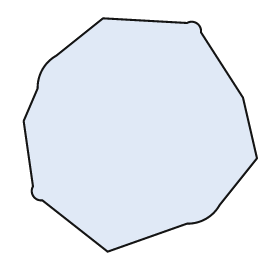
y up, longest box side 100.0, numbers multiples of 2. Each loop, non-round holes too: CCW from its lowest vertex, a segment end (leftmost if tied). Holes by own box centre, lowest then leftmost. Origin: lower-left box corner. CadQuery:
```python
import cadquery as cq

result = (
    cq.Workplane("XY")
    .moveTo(36.0, 0.0)
    .lineTo(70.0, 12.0)
    .threePointArc((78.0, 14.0), (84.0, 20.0))
    .lineTo(100.0, 40.0)
    .lineTo(94.0, 66.0)
    .lineTo(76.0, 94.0)
    .threePointArc((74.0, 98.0), (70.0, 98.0))
    .lineTo(34.0, 100.0)
    .lineTo(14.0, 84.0)
    .threePointArc((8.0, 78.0), (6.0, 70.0))
    .lineTo(0.0, 56.0)
    .lineTo(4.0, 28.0)
    .threePointArc((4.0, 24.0), (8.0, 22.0))
    .close()
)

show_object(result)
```